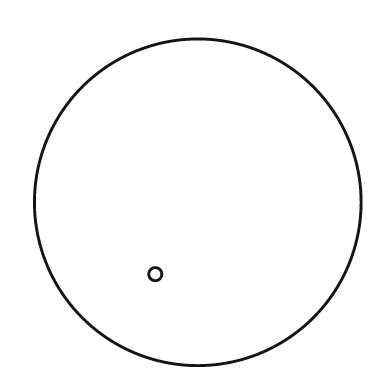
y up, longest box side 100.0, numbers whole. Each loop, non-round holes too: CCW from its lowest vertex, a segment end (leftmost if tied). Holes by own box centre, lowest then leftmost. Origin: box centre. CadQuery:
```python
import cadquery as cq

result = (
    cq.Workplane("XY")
    .moveTo(0.0, 0.0)
    .circle(50.0)
    .moveTo(-13.0, -22.0)
    .circle(2.0)
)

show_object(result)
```